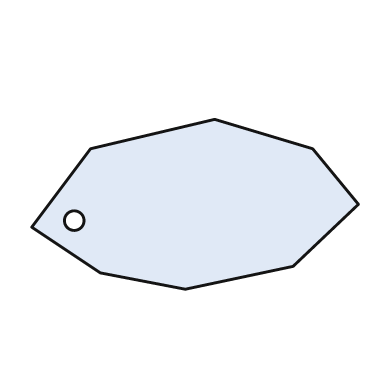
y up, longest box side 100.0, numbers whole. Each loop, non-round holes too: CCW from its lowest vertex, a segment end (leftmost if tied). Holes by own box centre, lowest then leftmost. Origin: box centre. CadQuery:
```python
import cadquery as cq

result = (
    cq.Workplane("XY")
    .moveTo(-3.0, -26.0)
    .lineTo(30.0, -19.0)
    .lineTo(50.0, 0.0)
    .lineTo(36.0, 17.0)
    .lineTo(6.0, 26.0)
    .lineTo(-32.0, 17.0)
    .lineTo(-50.0, -7.0)
    .lineTo(-29.0, -21.0)
    .close()
    .moveTo(-37.0, -5.0)
    .circle(3.0)
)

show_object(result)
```